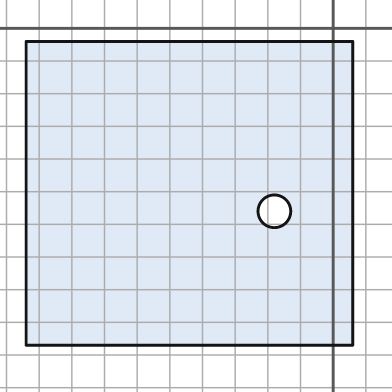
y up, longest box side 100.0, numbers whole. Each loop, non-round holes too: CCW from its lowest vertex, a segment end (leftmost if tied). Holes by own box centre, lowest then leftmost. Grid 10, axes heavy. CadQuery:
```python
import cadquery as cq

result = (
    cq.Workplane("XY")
    .moveTo(-94.0, -97.0)
    .lineTo(6.0, -97.0)
    .lineTo(6.0, -4.0)
    .lineTo(-94.0, -4.0)
    .close()
    .moveTo(-18.0, -56.0)
    .circle(5.0)
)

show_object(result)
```